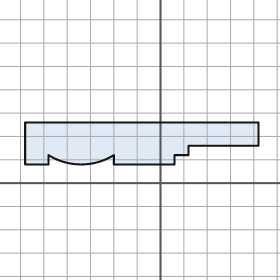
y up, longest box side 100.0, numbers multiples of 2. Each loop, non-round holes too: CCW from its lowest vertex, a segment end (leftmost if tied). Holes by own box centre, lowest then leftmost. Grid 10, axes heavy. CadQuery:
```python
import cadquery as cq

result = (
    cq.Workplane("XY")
    .moveTo(-58.0, 8.0)
    .lineTo(-48.0, 8.0)
    .lineTo(-48.0, 12.0)
    .threePointArc((-34.0, 8.0), (-20.0, 12.0))
    .lineTo(-20.0, 8.0)
    .lineTo(6.0, 8.0)
    .lineTo(6.0, 12.0)
    .lineTo(12.0, 12.0)
    .lineTo(12.0, 16.0)
    .lineTo(42.0, 16.0)
    .lineTo(42.0, 26.0)
    .lineTo(-58.0, 26.0)
    .close()
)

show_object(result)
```